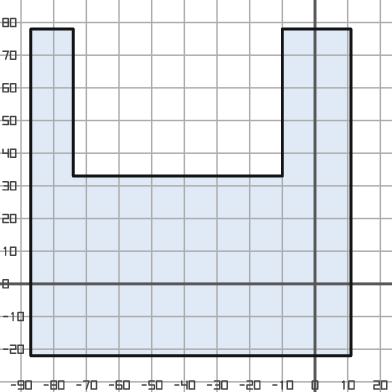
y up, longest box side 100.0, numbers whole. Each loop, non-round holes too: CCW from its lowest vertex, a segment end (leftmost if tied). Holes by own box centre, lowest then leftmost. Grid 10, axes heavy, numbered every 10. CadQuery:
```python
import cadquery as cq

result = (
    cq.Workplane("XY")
    .moveTo(-87.0, -22.0)
    .lineTo(11.0, -22.0)
    .lineTo(11.0, 78.0)
    .lineTo(-10.0, 78.0)
    .lineTo(-10.0, 33.0)
    .lineTo(-74.0, 33.0)
    .lineTo(-74.0, 78.0)
    .lineTo(-87.0, 78.0)
    .close()
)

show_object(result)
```